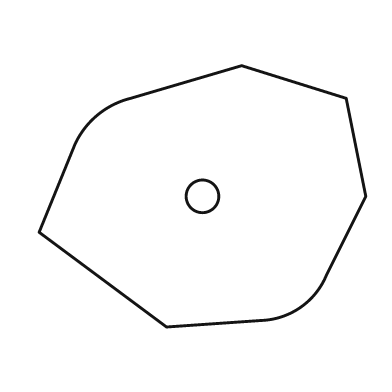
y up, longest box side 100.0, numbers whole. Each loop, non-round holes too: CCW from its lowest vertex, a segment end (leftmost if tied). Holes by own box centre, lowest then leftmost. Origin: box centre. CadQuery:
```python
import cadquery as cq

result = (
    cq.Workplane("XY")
    .moveTo(-11.0, -40.0)
    .lineTo(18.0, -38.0)
    .threePointArc((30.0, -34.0), (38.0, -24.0))
    .lineTo(50.0, 0.0)
    .lineTo(44.0, 30.0)
    .lineTo(12.0, 40.0)
    .lineTo(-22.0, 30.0)
    .threePointArc((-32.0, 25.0), (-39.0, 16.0))
    .lineTo(-50.0, -11.0)
    .close()
    .moveTo(0.0, 0.0)
    .circle(5.0)
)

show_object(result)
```